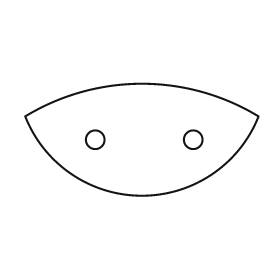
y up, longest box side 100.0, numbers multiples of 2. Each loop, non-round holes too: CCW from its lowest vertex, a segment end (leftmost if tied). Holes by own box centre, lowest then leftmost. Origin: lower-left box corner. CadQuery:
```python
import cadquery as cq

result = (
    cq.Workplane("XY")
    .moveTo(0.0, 34.0)
    .threePointArc((50.0, 0.0), (100.0, 34.0))
    .threePointArc((50.0, 48.0), (0.0, 34.0))
    .close()
    .moveTo(30.0, 24.0)
    .circle(4.0)
    .moveTo(72.0, 24.0)
    .circle(4.0)
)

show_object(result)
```